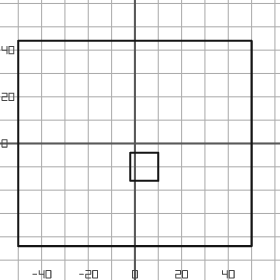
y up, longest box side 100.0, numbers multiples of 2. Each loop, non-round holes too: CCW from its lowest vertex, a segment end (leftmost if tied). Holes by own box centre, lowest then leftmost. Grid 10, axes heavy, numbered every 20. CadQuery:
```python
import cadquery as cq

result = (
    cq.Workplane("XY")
    .moveTo(-50.0, -44.0)
    .lineTo(50.0, -44.0)
    .lineTo(50.0, 44.0)
    .lineTo(-50.0, 44.0)
    .close()
    .moveTo(-2.0, -16.0)
    .lineTo(10.0, -16.0)
    .lineTo(10.0, -4.0)
    .lineTo(-2.0, -4.0)
    .close()
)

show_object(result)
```